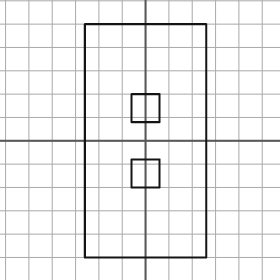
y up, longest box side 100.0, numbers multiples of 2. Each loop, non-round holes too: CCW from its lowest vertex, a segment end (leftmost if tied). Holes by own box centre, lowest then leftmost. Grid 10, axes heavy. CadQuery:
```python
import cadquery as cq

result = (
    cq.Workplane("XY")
    .moveTo(-26.0, -50.0)
    .lineTo(26.0, -50.0)
    .lineTo(26.0, 50.0)
    .lineTo(-26.0, 50.0)
    .close()
    .moveTo(-6.0, -20.0)
    .lineTo(6.0, -20.0)
    .lineTo(6.0, -8.0)
    .lineTo(-6.0, -8.0)
    .close()
    .moveTo(-6.0, 8.0)
    .lineTo(6.0, 8.0)
    .lineTo(6.0, 20.0)
    .lineTo(-6.0, 20.0)
    .close()
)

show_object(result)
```